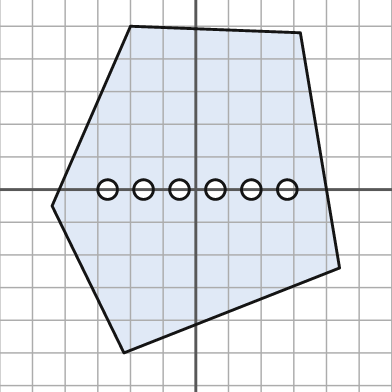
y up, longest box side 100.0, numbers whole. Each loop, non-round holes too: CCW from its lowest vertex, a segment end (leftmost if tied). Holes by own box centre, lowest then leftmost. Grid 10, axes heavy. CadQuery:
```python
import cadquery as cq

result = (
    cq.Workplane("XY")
    .moveTo(-22.0, -50.0)
    .lineTo(44.0, -24.0)
    .lineTo(32.0, 48.0)
    .lineTo(-20.0, 50.0)
    .lineTo(-44.0, -5.0)
    .close()
    .moveTo(-27.0, 0.0)
    .circle(3.0)
    .moveTo(-16.0, 0.0)
    .circle(3.0)
    .moveTo(-5.0, 0.0)
    .circle(3.0)
    .moveTo(6.0, 0.0)
    .circle(3.0)
    .moveTo(17.0, 0.0)
    .circle(3.0)
    .moveTo(28.0, 0.0)
    .circle(3.0)
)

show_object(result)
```